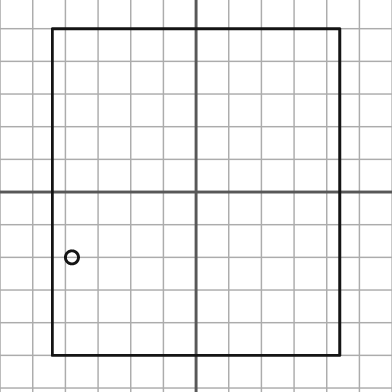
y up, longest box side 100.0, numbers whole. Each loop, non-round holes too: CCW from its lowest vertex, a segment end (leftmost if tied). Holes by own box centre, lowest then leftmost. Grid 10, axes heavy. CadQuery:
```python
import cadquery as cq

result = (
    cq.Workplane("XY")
    .moveTo(-44.0, -50.0)
    .lineTo(44.0, -50.0)
    .lineTo(44.0, 50.0)
    .lineTo(-44.0, 50.0)
    .close()
    .moveTo(-38.0, -20.0)
    .circle(2.0)
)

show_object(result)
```